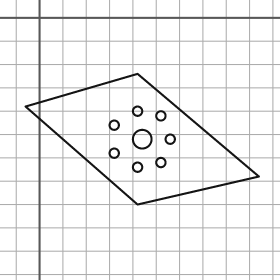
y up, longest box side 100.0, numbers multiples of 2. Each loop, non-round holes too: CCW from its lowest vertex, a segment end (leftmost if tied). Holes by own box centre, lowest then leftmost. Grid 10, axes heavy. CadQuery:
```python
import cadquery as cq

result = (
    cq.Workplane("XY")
    .moveTo(42.0, -80.0)
    .lineTo(94.0, -68.0)
    .lineTo(42.0, -24.0)
    .lineTo(-6.0, -38.0)
    .close()
    .moveTo(42.0, -64.0)
    .circle(2.0)
    .moveTo(52.0, -62.0)
    .circle(2.0)
    .moveTo(32.0, -58.0)
    .circle(2.0)
    .moveTo(44.0, -52.0)
    .circle(4.0)
    .moveTo(56.0, -52.0)
    .circle(2.0)
    .moveTo(32.0, -46.0)
    .circle(2.0)
    .moveTo(52.0, -42.0)
    .circle(2.0)
    .moveTo(42.0, -40.0)
    .circle(2.0)
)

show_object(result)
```